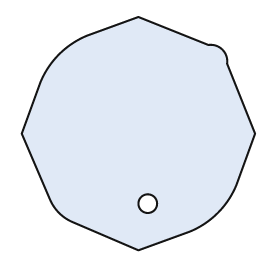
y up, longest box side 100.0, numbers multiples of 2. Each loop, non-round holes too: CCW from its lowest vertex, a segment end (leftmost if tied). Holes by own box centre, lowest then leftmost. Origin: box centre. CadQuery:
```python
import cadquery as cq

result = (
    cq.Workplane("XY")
    .moveTo(0.0, -50.0)
    .lineTo(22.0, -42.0)
    .threePointArc((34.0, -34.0), (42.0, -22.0))
    .lineTo(50.0, 0.0)
    .lineTo(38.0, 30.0)
    .threePointArc((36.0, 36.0), (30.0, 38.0))
    .lineTo(0.0, 50.0)
    .lineTo(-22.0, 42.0)
    .threePointArc((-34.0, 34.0), (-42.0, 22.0))
    .lineTo(-50.0, 0.0)
    .lineTo(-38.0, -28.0)
    .threePointArc((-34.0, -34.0), (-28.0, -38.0))
    .close()
    .moveTo(4.0, -30.0)
    .circle(4.0)
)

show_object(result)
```